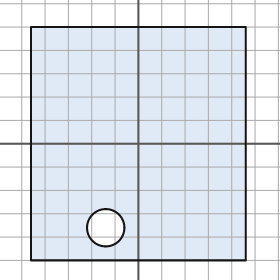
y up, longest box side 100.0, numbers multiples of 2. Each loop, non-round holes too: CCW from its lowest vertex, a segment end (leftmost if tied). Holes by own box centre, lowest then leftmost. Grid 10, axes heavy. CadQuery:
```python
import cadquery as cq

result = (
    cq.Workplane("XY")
    .moveTo(-46.0, -50.0)
    .lineTo(46.0, -50.0)
    .lineTo(46.0, 50.0)
    .lineTo(-46.0, 50.0)
    .close()
    .moveTo(-14.0, -36.0)
    .circle(8.0)
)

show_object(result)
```